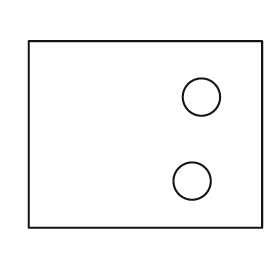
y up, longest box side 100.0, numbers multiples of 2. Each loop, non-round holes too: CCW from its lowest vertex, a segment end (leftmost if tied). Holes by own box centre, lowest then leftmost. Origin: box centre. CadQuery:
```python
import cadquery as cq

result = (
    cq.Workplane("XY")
    .moveTo(-50.0, -40.0)
    .lineTo(50.0, -40.0)
    .lineTo(50.0, 40.0)
    .lineTo(-50.0, 40.0)
    .close()
    .moveTo(20.0, -20.0)
    .circle(8.0)
    .moveTo(24.0, 16.0)
    .circle(8.0)
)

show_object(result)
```